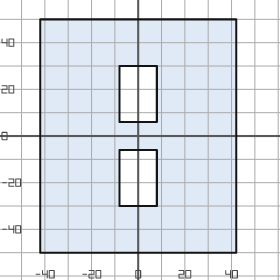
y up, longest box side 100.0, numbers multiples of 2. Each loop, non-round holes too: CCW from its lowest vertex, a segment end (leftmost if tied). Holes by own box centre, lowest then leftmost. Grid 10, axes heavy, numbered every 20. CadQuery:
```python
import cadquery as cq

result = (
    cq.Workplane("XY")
    .moveTo(-42.0, -50.0)
    .lineTo(42.0, -50.0)
    .lineTo(42.0, 50.0)
    .lineTo(-42.0, 50.0)
    .close()
    .moveTo(-8.0, -30.0)
    .lineTo(8.0, -30.0)
    .lineTo(8.0, -6.0)
    .lineTo(-8.0, -6.0)
    .close()
    .moveTo(-8.0, 6.0)
    .lineTo(8.0, 6.0)
    .lineTo(8.0, 30.0)
    .lineTo(-8.0, 30.0)
    .close()
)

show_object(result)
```